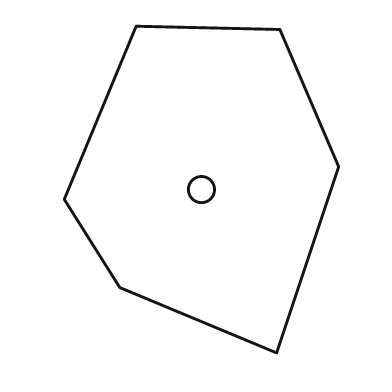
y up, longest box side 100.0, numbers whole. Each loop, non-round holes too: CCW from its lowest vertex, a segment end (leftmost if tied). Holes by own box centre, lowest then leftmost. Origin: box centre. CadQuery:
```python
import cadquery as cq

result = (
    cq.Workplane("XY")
    .moveTo(23.0, -50.0)
    .lineTo(42.0, 7.0)
    .lineTo(24.0, 49.0)
    .lineTo(-20.0, 50.0)
    .lineTo(-42.0, -3.0)
    .lineTo(-25.0, -30.0)
    .close()
    .moveTo(0.0, 0.0)
    .circle(4.0)
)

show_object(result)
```